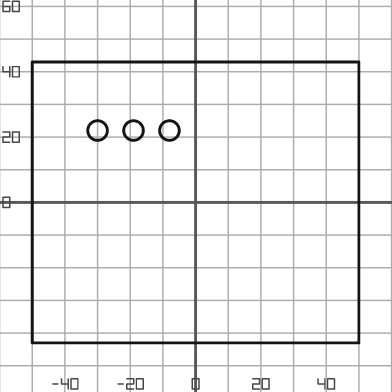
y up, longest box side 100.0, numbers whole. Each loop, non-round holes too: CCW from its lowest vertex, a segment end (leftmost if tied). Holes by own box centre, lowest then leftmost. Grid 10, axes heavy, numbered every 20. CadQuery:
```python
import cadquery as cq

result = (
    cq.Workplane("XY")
    .moveTo(-50.0, -43.0)
    .lineTo(50.0, -43.0)
    .lineTo(50.0, 43.0)
    .lineTo(-50.0, 43.0)
    .close()
    .moveTo(-30.0, 22.0)
    .circle(3.0)
    .moveTo(-19.0, 22.0)
    .circle(3.0)
    .moveTo(-8.0, 22.0)
    .circle(3.0)
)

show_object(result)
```